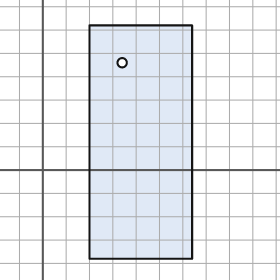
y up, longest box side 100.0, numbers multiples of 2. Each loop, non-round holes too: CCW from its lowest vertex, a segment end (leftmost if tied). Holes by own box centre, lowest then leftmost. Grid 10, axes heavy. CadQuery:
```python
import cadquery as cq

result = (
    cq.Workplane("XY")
    .moveTo(20.0, -38.0)
    .lineTo(64.0, -38.0)
    .lineTo(64.0, 62.0)
    .lineTo(20.0, 62.0)
    .close()
    .moveTo(34.0, 46.0)
    .circle(2.0)
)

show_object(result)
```